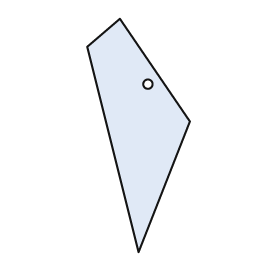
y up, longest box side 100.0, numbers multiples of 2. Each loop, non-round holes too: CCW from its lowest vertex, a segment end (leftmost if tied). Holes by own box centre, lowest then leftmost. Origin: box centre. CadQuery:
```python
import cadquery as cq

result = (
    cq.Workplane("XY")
    .moveTo(0.0, -50.0)
    .lineTo(22.0, 6.0)
    .lineTo(-8.0, 50.0)
    .lineTo(-22.0, 38.0)
    .close()
    .moveTo(4.0, 22.0)
    .circle(2.0)
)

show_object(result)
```